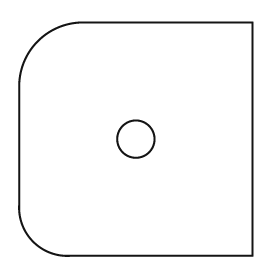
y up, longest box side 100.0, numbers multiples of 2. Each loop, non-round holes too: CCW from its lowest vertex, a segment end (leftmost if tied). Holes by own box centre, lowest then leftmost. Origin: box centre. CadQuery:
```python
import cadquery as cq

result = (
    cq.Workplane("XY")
    .moveTo(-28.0, -50.0)
    .lineTo(50.0, -50.0)
    .lineTo(50.0, 50.0)
    .lineTo(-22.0, 50.0)
    .threePointArc((-42.0, 42.0), (-50.0, 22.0))
    .lineTo(-50.0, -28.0)
    .threePointArc((-44.0, -44.0), (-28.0, -50.0))
    .close()
    .moveTo(0.0, 0.0)
    .circle(8.0)
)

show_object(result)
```